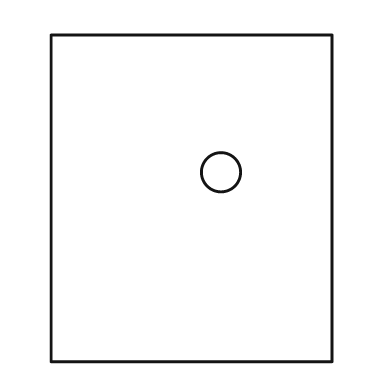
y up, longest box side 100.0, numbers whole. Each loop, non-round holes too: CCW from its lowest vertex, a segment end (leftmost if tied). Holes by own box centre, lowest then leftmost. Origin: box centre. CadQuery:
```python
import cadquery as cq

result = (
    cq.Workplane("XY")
    .moveTo(-43.0, -50.0)
    .lineTo(43.0, -50.0)
    .lineTo(43.0, 50.0)
    .lineTo(-43.0, 50.0)
    .close()
    .moveTo(9.0, 8.0)
    .circle(6.0)
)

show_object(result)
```